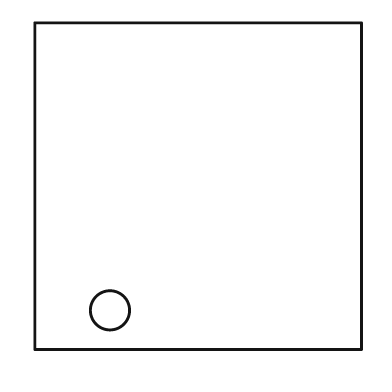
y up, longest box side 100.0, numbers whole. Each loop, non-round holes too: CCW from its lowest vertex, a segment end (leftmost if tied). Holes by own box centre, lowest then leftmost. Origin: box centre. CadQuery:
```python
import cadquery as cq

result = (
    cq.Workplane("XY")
    .moveTo(-50.0, -50.0)
    .lineTo(50.0, -50.0)
    .lineTo(50.0, 50.0)
    .lineTo(-50.0, 50.0)
    .close()
    .moveTo(-27.0, -38.0)
    .circle(6.0)
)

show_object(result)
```